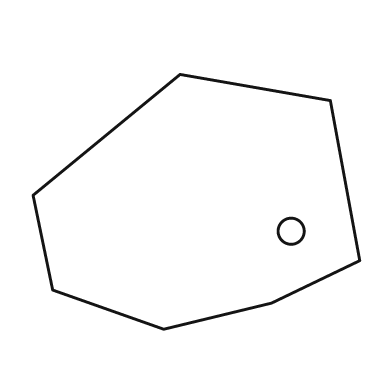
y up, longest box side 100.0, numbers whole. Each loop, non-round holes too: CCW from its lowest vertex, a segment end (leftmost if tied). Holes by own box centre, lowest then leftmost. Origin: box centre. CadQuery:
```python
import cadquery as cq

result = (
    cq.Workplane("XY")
    .moveTo(-10.0, -39.0)
    .lineTo(23.0, -31.0)
    .lineTo(50.0, -18.0)
    .lineTo(41.0, 31.0)
    .lineTo(-5.0, 39.0)
    .lineTo(-50.0, 2.0)
    .lineTo(-44.0, -27.0)
    .close()
    .moveTo(29.0, -9.0)
    .circle(4.0)
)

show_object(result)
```